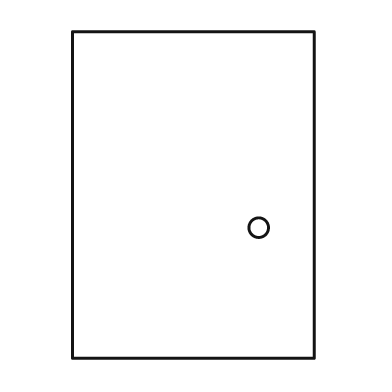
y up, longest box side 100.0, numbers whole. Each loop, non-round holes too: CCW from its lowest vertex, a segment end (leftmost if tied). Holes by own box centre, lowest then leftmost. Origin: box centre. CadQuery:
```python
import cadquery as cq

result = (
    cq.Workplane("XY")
    .moveTo(-37.0, -50.0)
    .lineTo(37.0, -50.0)
    .lineTo(37.0, 50.0)
    .lineTo(-37.0, 50.0)
    .close()
    .moveTo(20.0, -10.0)
    .circle(3.0)
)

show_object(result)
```